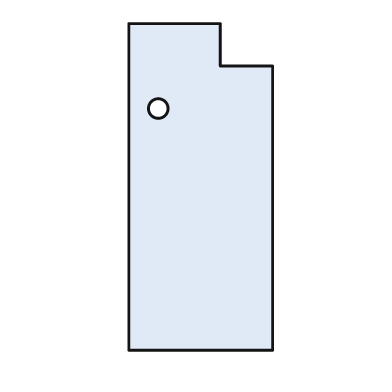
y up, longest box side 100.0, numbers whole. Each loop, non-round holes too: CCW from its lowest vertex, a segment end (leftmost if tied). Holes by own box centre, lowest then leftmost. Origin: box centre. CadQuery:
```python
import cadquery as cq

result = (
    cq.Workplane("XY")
    .moveTo(-22.0, -50.0)
    .lineTo(22.0, -50.0)
    .lineTo(22.0, 37.0)
    .lineTo(6.0, 37.0)
    .lineTo(6.0, 50.0)
    .lineTo(-22.0, 50.0)
    .close()
    .moveTo(-13.0, 24.0)
    .circle(3.0)
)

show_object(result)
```